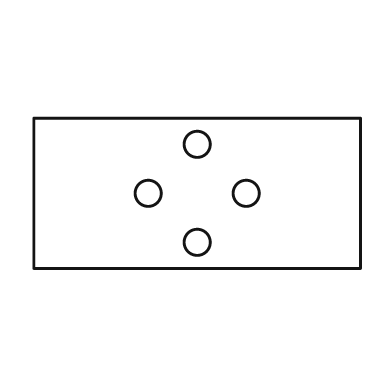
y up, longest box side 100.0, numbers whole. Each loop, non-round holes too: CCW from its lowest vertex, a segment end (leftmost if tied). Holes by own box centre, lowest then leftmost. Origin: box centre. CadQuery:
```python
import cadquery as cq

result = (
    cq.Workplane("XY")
    .moveTo(-50.0, -23.0)
    .lineTo(50.0, -23.0)
    .lineTo(50.0, 23.0)
    .lineTo(-50.0, 23.0)
    .close()
    .moveTo(0.0, -15.0)
    .circle(4.0)
    .moveTo(-15.0, 0.0)
    .circle(4.0)
    .moveTo(15.0, 0.0)
    .circle(4.0)
    .moveTo(0.0, 15.0)
    .circle(4.0)
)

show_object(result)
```